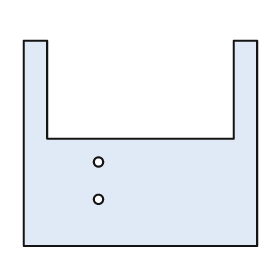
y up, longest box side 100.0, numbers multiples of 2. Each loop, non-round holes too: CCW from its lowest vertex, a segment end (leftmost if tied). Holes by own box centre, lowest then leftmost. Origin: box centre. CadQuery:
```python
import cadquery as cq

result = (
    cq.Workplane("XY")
    .moveTo(-50.0, -44.0)
    .lineTo(50.0, -44.0)
    .lineTo(50.0, 44.0)
    .lineTo(40.0, 44.0)
    .lineTo(40.0, 2.0)
    .lineTo(-40.0, 2.0)
    .lineTo(-40.0, 44.0)
    .lineTo(-50.0, 44.0)
    .close()
    .moveTo(-18.0, -24.0)
    .circle(2.0)
    .moveTo(-18.0, -8.0)
    .circle(2.0)
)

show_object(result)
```